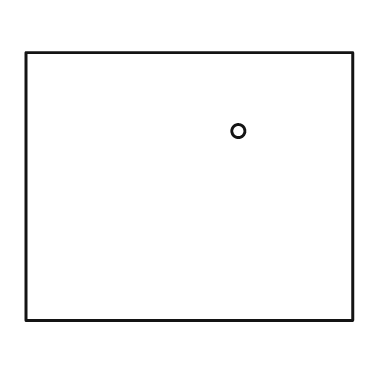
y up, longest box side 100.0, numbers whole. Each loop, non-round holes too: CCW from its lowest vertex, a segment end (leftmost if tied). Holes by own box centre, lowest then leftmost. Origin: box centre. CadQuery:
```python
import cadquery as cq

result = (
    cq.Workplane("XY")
    .moveTo(-50.0, -41.0)
    .lineTo(50.0, -41.0)
    .lineTo(50.0, 41.0)
    .lineTo(-50.0, 41.0)
    .close()
    .moveTo(15.0, 17.0)
    .circle(2.0)
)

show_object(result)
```